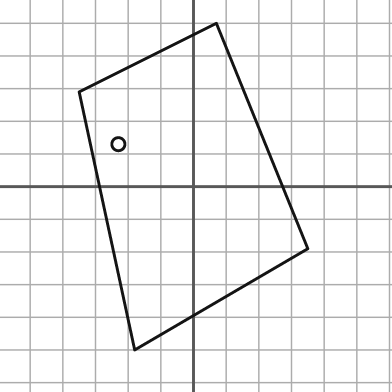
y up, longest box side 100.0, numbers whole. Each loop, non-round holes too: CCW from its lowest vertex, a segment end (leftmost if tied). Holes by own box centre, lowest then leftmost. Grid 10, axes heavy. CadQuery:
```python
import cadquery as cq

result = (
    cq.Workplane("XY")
    .moveTo(-18.0, -50.0)
    .lineTo(35.0, -19.0)
    .lineTo(7.0, 50.0)
    .lineTo(-35.0, 29.0)
    .close()
    .moveTo(-23.0, 13.0)
    .circle(2.0)
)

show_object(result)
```